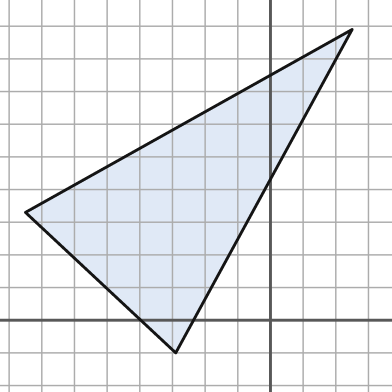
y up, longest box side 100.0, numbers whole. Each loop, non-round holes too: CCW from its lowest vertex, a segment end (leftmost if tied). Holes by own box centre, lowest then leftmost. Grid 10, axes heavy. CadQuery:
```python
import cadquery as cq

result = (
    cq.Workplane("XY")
    .moveTo(-29.0, -10.0)
    .lineTo(25.0, 89.0)
    .lineTo(-75.0, 33.0)
    .close()
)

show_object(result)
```